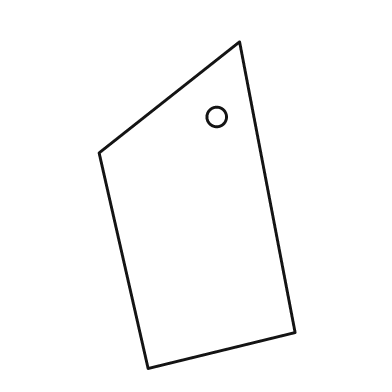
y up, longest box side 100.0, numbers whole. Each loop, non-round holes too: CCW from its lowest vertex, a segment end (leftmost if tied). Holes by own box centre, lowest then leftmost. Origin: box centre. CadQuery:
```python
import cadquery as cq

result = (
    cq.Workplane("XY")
    .moveTo(-15.0, -50.0)
    .lineTo(30.0, -39.0)
    .lineTo(13.0, 50.0)
    .lineTo(-30.0, 16.0)
    .close()
    .moveTo(6.0, 27.0)
    .circle(3.0)
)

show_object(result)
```